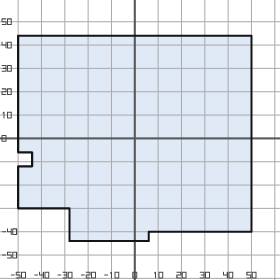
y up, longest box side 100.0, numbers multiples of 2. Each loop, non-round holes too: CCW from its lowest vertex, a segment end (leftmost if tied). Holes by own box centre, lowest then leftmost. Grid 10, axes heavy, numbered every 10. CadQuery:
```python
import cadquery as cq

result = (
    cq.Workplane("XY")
    .moveTo(-28.0, -44.0)
    .lineTo(6.0, -44.0)
    .lineTo(6.0, -40.0)
    .lineTo(50.0, -40.0)
    .lineTo(50.0, 44.0)
    .lineTo(-50.0, 44.0)
    .lineTo(-50.0, -6.0)
    .lineTo(-44.0, -6.0)
    .lineTo(-44.0, -12.0)
    .lineTo(-50.0, -12.0)
    .lineTo(-50.0, -30.0)
    .lineTo(-28.0, -30.0)
    .close()
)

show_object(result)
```